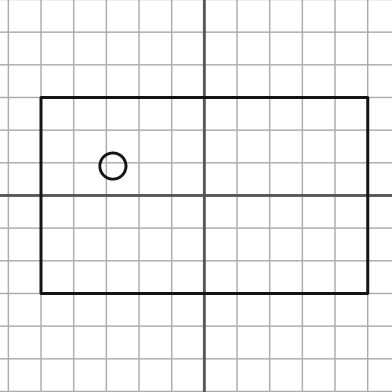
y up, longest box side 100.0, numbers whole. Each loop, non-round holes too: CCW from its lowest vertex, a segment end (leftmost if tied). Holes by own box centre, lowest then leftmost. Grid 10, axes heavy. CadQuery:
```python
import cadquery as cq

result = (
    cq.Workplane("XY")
    .moveTo(-50.0, -30.0)
    .lineTo(50.0, -30.0)
    .lineTo(50.0, 30.0)
    .lineTo(-50.0, 30.0)
    .close()
    .moveTo(-28.0, 9.0)
    .circle(4.0)
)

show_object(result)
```